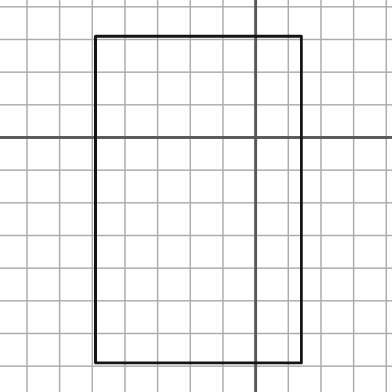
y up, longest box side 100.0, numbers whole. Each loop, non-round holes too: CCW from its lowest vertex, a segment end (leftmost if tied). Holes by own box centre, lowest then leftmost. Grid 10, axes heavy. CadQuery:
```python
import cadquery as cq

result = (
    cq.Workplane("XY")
    .moveTo(-49.0, -69.0)
    .lineTo(14.0, -69.0)
    .lineTo(14.0, 31.0)
    .lineTo(-49.0, 31.0)
    .close()
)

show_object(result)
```